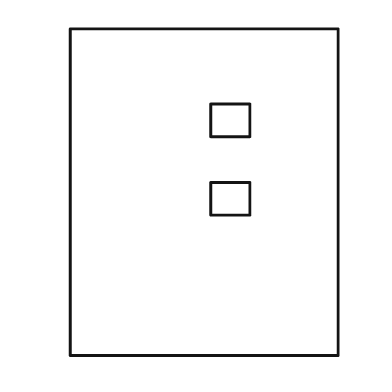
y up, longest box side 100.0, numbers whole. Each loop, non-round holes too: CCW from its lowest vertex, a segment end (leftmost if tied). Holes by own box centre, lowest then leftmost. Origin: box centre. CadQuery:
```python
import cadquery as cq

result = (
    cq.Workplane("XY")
    .moveTo(-41.0, -50.0)
    .lineTo(41.0, -50.0)
    .lineTo(41.0, 50.0)
    .lineTo(-41.0, 50.0)
    .close()
    .moveTo(2.0, -7.0)
    .lineTo(14.0, -7.0)
    .lineTo(14.0, 3.0)
    .lineTo(2.0, 3.0)
    .close()
    .moveTo(2.0, 17.0)
    .lineTo(14.0, 17.0)
    .lineTo(14.0, 27.0)
    .lineTo(2.0, 27.0)
    .close()
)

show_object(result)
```